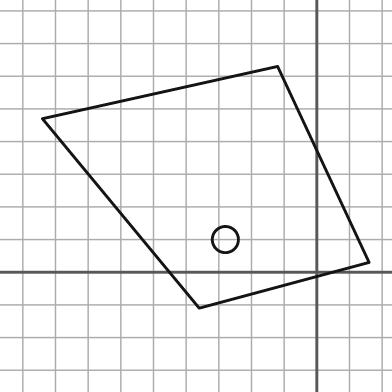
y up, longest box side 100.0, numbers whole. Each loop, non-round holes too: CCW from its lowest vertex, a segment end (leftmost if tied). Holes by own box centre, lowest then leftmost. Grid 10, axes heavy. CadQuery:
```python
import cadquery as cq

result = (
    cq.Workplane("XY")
    .moveTo(-36.0, -11.0)
    .lineTo(16.0, 3.0)
    .lineTo(-12.0, 63.0)
    .lineTo(-84.0, 47.0)
    .close()
    .moveTo(-28.0, 10.0)
    .circle(4.0)
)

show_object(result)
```